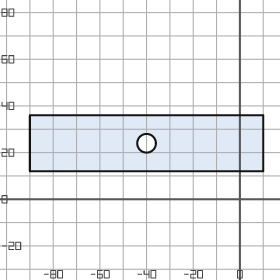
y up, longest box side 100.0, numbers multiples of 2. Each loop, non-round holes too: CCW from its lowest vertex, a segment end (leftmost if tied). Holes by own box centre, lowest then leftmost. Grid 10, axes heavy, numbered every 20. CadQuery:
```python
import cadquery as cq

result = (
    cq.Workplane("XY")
    .moveTo(-90.0, 12.0)
    .lineTo(10.0, 12.0)
    .lineTo(10.0, 36.0)
    .lineTo(-90.0, 36.0)
    .close()
    .moveTo(-40.0, 24.0)
    .circle(4.0)
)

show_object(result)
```